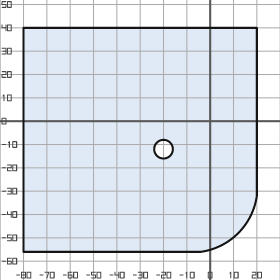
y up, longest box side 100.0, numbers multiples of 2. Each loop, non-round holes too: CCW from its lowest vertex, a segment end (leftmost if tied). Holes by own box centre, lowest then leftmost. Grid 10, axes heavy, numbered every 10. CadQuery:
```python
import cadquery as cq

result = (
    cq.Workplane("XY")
    .moveTo(-80.0, -56.0)
    .lineTo(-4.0, -56.0)
    .threePointArc((12.0, -48.0), (20.0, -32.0))
    .lineTo(20.0, 40.0)
    .lineTo(-80.0, 40.0)
    .close()
    .moveTo(-20.0, -12.0)
    .circle(4.0)
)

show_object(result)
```